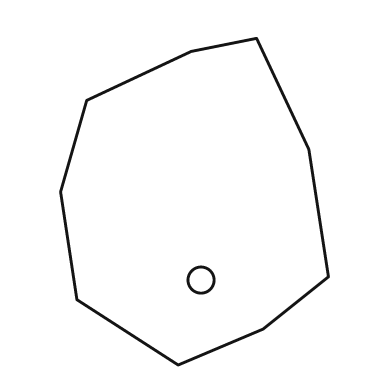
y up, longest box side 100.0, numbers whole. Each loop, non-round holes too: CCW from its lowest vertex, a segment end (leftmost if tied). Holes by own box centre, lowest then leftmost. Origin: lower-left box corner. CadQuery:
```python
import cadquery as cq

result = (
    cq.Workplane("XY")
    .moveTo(36.0, 0.0)
    .lineTo(62.0, 11.0)
    .lineTo(82.0, 27.0)
    .lineTo(76.0, 66.0)
    .lineTo(60.0, 100.0)
    .lineTo(40.0, 96.0)
    .lineTo(8.0, 81.0)
    .lineTo(0.0, 53.0)
    .lineTo(5.0, 20.0)
    .close()
    .moveTo(43.0, 26.0)
    .circle(4.0)
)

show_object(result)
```